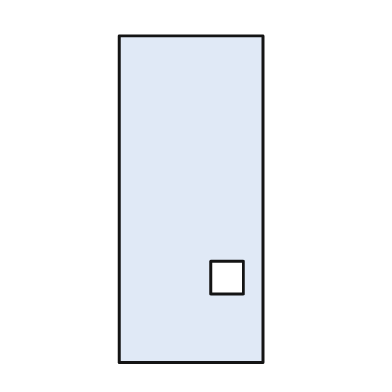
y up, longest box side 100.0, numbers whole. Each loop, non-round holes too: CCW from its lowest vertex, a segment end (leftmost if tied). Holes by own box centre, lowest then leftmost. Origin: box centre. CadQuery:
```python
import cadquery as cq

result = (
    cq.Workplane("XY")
    .moveTo(-22.0, -50.0)
    .lineTo(22.0, -50.0)
    .lineTo(22.0, 50.0)
    .lineTo(-22.0, 50.0)
    .close()
    .moveTo(6.0, -29.0)
    .lineTo(16.0, -29.0)
    .lineTo(16.0, -19.0)
    .lineTo(6.0, -19.0)
    .close()
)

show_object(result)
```